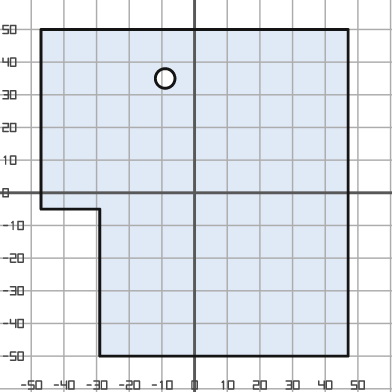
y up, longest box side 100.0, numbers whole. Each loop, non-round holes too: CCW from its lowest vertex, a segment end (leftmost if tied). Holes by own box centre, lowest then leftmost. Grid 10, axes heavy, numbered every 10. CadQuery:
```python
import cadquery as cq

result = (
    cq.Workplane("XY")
    .moveTo(-29.0, -50.0)
    .lineTo(47.0, -50.0)
    .lineTo(47.0, 50.0)
    .lineTo(-47.0, 50.0)
    .lineTo(-47.0, -5.0)
    .lineTo(-29.0, -5.0)
    .close()
    .moveTo(-9.0, 35.0)
    .circle(3.0)
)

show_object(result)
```